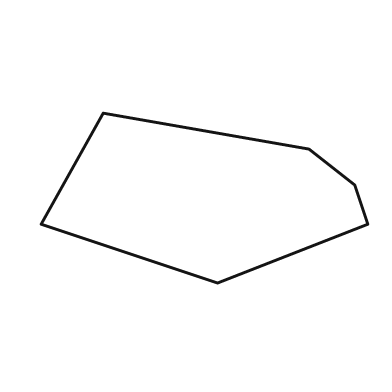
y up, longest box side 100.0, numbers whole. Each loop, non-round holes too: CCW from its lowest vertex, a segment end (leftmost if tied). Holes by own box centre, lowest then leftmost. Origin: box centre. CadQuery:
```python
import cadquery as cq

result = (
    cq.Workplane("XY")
    .moveTo(4.0, -26.0)
    .lineTo(50.0, -8.0)
    .lineTo(46.0, 4.0)
    .lineTo(32.0, 15.0)
    .lineTo(-31.0, 26.0)
    .lineTo(-50.0, -8.0)
    .close()
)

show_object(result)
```